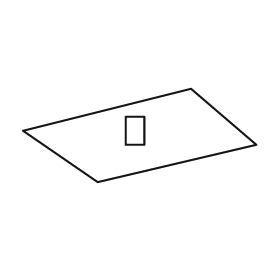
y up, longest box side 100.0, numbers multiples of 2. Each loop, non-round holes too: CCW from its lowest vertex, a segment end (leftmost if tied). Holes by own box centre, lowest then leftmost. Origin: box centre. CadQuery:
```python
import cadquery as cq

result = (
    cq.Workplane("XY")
    .moveTo(-18.0, -20.0)
    .lineTo(50.0, -4.0)
    .lineTo(22.0, 20.0)
    .lineTo(-50.0, 2.0)
    .close()
    .moveTo(-6.0, -4.0)
    .lineTo(2.0, -4.0)
    .lineTo(2.0, 8.0)
    .lineTo(-6.0, 8.0)
    .close()
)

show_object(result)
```